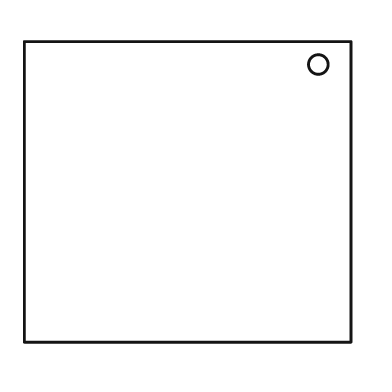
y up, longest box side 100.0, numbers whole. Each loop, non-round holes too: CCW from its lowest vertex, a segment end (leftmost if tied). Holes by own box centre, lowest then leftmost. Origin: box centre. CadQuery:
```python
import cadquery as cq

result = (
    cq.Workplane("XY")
    .moveTo(-50.0, -46.0)
    .lineTo(50.0, -46.0)
    .lineTo(50.0, 46.0)
    .lineTo(-50.0, 46.0)
    .close()
    .moveTo(40.0, 39.0)
    .circle(3.0)
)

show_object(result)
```